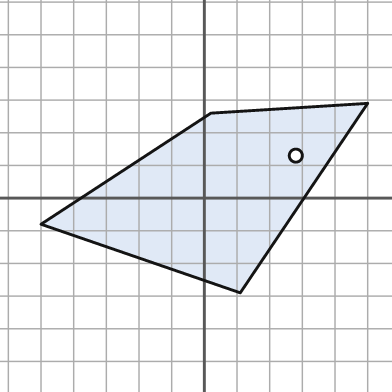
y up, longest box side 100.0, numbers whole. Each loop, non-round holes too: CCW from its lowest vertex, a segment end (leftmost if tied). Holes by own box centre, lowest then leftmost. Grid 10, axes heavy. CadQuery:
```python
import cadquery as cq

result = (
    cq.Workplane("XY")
    .moveTo(11.0, -29.0)
    .lineTo(50.0, 29.0)
    .lineTo(2.0, 26.0)
    .lineTo(-50.0, -8.0)
    .close()
    .moveTo(28.0, 13.0)
    .circle(2.0)
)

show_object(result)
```